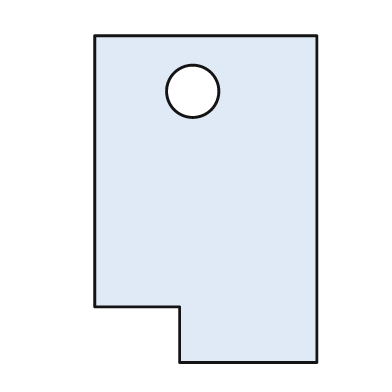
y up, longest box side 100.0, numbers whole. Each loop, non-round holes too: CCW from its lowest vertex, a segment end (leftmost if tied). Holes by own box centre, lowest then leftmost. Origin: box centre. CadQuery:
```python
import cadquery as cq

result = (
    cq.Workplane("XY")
    .moveTo(-8.0, -50.0)
    .lineTo(34.0, -50.0)
    .lineTo(34.0, 50.0)
    .lineTo(-34.0, 50.0)
    .lineTo(-34.0, -33.0)
    .lineTo(-8.0, -33.0)
    .close()
    .moveTo(-4.0, 33.0)
    .circle(8.0)
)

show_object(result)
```